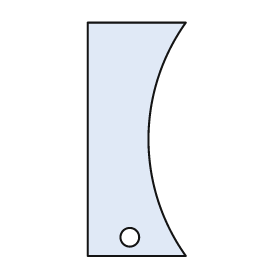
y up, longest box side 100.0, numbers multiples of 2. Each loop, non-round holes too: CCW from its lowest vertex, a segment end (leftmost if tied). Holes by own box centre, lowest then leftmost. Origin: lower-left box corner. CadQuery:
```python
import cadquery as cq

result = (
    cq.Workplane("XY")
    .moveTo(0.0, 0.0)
    .lineTo(42.0, 0.0)
    .threePointArc((26.0, 50.0), (42.0, 100.0))
    .lineTo(0.0, 100.0)
    .close()
    .moveTo(18.0, 8.0)
    .circle(4.0)
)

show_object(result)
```